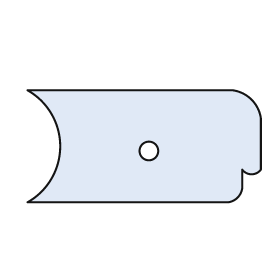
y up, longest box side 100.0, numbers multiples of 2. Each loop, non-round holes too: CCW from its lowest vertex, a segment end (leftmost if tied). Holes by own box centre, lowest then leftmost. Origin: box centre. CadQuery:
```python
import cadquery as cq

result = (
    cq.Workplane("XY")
    .moveTo(-50.0, -24.0)
    .lineTo(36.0, -24.0)
    .threePointArc((40.0, -22.0), (42.0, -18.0))
    .lineTo(42.0, -10.0)
    .threePointArc((46.0, -12.0), (50.0, -10.0))
    .lineTo(50.0, 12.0)
    .threePointArc((46.0, 20.0), (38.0, 24.0))
    .lineTo(-50.0, 24.0)
    .threePointArc((-36.0, 0.0), (-50.0, -24.0))
    .close()
    .moveTo(2.0, -2.0)
    .circle(4.0)
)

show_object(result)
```